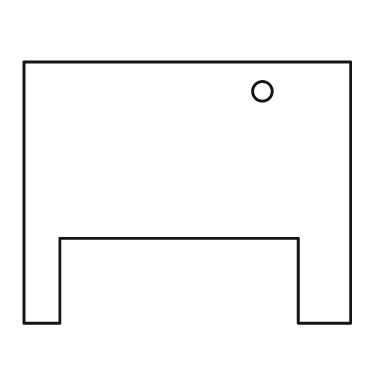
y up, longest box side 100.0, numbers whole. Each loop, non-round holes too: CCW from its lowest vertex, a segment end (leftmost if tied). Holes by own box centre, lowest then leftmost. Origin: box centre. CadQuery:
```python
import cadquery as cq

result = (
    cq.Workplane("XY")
    .moveTo(-50.0, -40.0)
    .lineTo(-39.0, -40.0)
    .lineTo(-39.0, -14.0)
    .lineTo(34.0, -14.0)
    .lineTo(34.0, -40.0)
    .lineTo(50.0, -40.0)
    .lineTo(50.0, 40.0)
    .lineTo(-50.0, 40.0)
    .close()
    .moveTo(23.0, 31.0)
    .circle(3.0)
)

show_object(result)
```